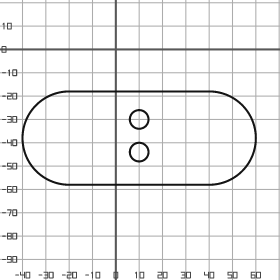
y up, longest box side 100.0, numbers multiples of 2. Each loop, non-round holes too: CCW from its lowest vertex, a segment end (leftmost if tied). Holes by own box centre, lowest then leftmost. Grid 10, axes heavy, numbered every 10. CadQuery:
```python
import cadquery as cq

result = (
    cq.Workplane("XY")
    .moveTo(-20.0, -58.0)
    .lineTo(40.0, -58.0)
    .threePointArc((60.0, -38.0), (40.0, -18.0))
    .lineTo(-20.0, -18.0)
    .threePointArc((-40.0, -38.0), (-20.0, -58.0))
    .close()
    .moveTo(10.0, -44.0)
    .circle(4.0)
    .moveTo(10.0, -30.0)
    .circle(4.0)
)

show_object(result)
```